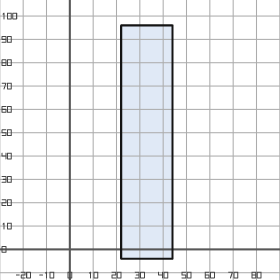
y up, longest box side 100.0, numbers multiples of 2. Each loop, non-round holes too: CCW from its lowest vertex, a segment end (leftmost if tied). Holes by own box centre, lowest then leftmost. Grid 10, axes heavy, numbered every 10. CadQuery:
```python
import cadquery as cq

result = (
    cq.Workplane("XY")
    .moveTo(22.0, -4.0)
    .lineTo(44.0, -4.0)
    .lineTo(44.0, 96.0)
    .lineTo(22.0, 96.0)
    .close()
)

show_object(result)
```